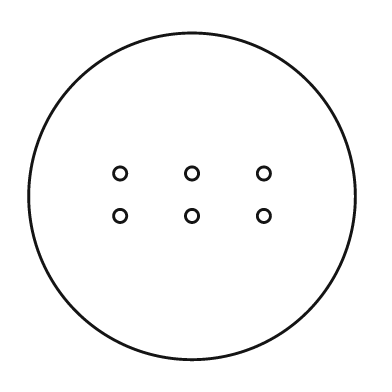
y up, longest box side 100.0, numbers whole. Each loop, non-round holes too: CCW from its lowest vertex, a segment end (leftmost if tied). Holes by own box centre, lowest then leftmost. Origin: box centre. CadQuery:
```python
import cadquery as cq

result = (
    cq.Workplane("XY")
    .moveTo(0.0, 0.0)
    .circle(50.0)
    .moveTo(-22.0, -6.0)
    .circle(2.0)
    .moveTo(0.0, -6.0)
    .circle(2.0)
    .moveTo(22.0, -6.0)
    .circle(2.0)
    .moveTo(-22.0, 7.0)
    .circle(2.0)
    .moveTo(0.0, 7.0)
    .circle(2.0)
    .moveTo(22.0, 7.0)
    .circle(2.0)
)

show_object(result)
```